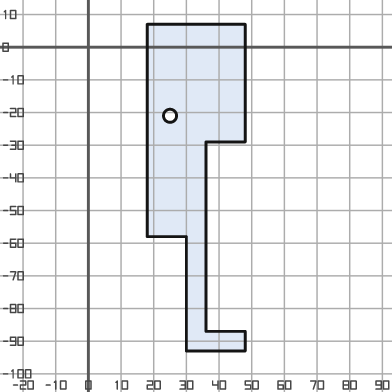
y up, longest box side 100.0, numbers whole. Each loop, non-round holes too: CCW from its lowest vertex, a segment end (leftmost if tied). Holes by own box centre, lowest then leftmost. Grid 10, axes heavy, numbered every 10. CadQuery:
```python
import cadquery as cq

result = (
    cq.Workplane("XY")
    .moveTo(30.0, -93.0)
    .lineTo(48.0, -93.0)
    .lineTo(48.0, -87.0)
    .lineTo(36.0, -87.0)
    .lineTo(36.0, -29.0)
    .lineTo(48.0, -29.0)
    .lineTo(48.0, 7.0)
    .lineTo(18.0, 7.0)
    .lineTo(18.0, -58.0)
    .lineTo(30.0, -58.0)
    .close()
    .moveTo(25.0, -21.0)
    .circle(2.0)
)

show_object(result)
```